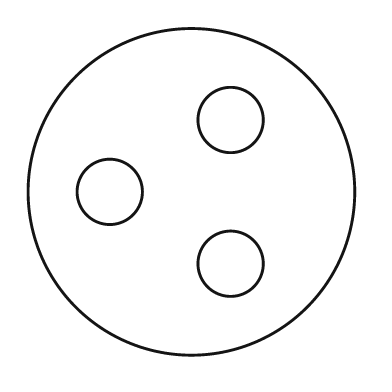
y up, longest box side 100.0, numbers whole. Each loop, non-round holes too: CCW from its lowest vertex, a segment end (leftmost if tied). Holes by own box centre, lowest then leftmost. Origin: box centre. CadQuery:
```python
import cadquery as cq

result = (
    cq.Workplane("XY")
    .moveTo(0.0, 0.0)
    .circle(50.0)
    .moveTo(12.0, -22.0)
    .circle(10.0)
    .moveTo(-25.0, 0.0)
    .circle(10.0)
    .moveTo(12.0, 22.0)
    .circle(10.0)
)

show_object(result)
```